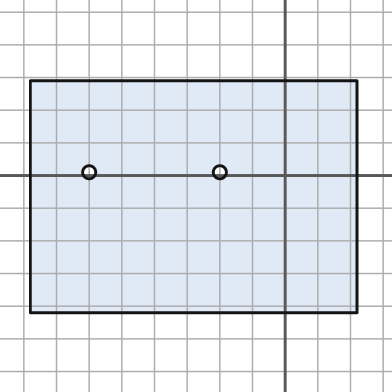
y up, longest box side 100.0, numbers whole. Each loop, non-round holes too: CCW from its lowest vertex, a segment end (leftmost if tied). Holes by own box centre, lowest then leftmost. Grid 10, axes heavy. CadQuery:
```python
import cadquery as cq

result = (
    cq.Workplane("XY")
    .moveTo(-78.0, -42.0)
    .lineTo(22.0, -42.0)
    .lineTo(22.0, 29.0)
    .lineTo(-78.0, 29.0)
    .close()
    .moveTo(-60.0, 1.0)
    .circle(2.0)
    .moveTo(-20.0, 1.0)
    .circle(2.0)
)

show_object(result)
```